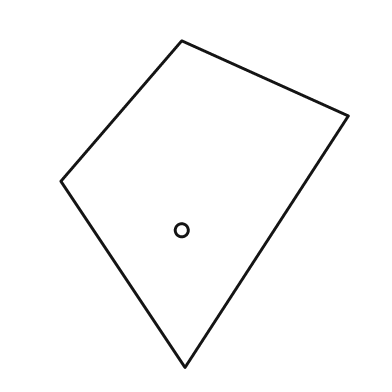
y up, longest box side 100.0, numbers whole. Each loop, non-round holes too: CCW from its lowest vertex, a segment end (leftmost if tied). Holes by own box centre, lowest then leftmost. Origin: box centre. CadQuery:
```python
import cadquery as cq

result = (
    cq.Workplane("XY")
    .moveTo(-6.0, -50.0)
    .lineTo(44.0, 27.0)
    .lineTo(-7.0, 50.0)
    .lineTo(-44.0, 7.0)
    .close()
    .moveTo(-7.0, -8.0)
    .circle(2.0)
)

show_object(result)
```